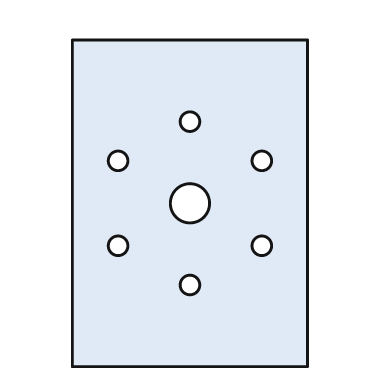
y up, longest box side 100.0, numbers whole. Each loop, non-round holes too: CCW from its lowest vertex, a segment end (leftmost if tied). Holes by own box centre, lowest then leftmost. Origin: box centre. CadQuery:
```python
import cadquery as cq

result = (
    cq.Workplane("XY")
    .moveTo(-36.0, -50.0)
    .lineTo(36.0, -50.0)
    .lineTo(36.0, 50.0)
    .lineTo(-36.0, 50.0)
    .close()
    .moveTo(0.0, -25.0)
    .circle(3.0)
    .moveTo(-22.0, -13.0)
    .circle(3.0)
    .moveTo(22.0, -13.0)
    .circle(3.0)
    .moveTo(0.0, 0.0)
    .circle(6.0)
    .moveTo(-22.0, 13.0)
    .circle(3.0)
    .moveTo(22.0, 13.0)
    .circle(3.0)
    .moveTo(0.0, 25.0)
    .circle(3.0)
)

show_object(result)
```